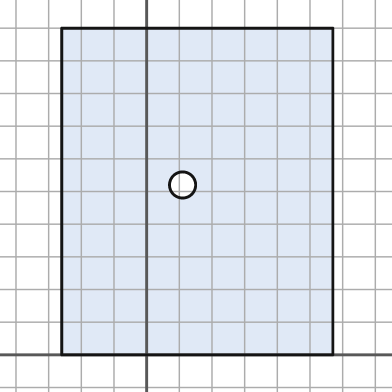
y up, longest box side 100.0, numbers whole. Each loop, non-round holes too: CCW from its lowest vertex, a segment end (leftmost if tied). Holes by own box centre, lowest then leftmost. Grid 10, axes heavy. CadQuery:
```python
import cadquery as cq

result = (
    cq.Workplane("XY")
    .moveTo(-26.0, 0.0)
    .lineTo(57.0, 0.0)
    .lineTo(57.0, 100.0)
    .lineTo(-26.0, 100.0)
    .close()
    .moveTo(11.0, 52.0)
    .circle(4.0)
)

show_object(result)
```